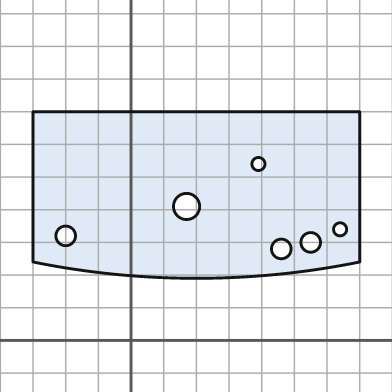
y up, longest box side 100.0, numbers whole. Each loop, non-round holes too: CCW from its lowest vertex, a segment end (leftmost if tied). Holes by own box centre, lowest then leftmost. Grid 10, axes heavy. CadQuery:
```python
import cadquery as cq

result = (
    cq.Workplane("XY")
    .moveTo(-30.0, 24.0)
    .threePointArc((20.0, 19.0), (70.0, 24.0))
    .lineTo(70.0, 70.0)
    .lineTo(-30.0, 70.0)
    .close()
    .moveTo(46.0, 28.0)
    .circle(3.0)
    .moveTo(55.0, 30.0)
    .circle(3.0)
    .moveTo(-20.0, 32.0)
    .circle(3.0)
    .moveTo(64.0, 34.0)
    .circle(2.0)
    .moveTo(17.0, 41.0)
    .circle(4.0)
    .moveTo(39.0, 54.0)
    .circle(2.0)
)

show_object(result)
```